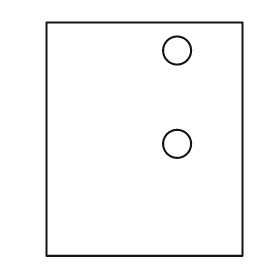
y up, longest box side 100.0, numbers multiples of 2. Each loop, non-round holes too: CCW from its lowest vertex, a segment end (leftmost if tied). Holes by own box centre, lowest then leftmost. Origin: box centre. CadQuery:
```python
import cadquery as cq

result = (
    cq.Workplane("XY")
    .moveTo(-42.0, -50.0)
    .lineTo(42.0, -50.0)
    .lineTo(42.0, 50.0)
    .lineTo(-42.0, 50.0)
    .close()
    .moveTo(14.0, -2.0)
    .circle(6.0)
    .moveTo(14.0, 38.0)
    .circle(6.0)
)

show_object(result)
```